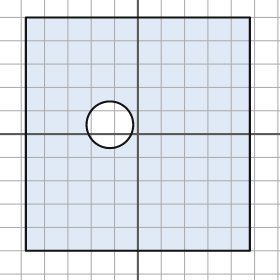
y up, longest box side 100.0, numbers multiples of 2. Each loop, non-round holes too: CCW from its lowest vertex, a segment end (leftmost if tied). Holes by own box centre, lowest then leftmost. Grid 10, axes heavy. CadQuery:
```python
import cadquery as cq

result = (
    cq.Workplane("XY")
    .moveTo(-48.0, -50.0)
    .lineTo(48.0, -50.0)
    .lineTo(48.0, 50.0)
    .lineTo(-48.0, 50.0)
    .close()
    .moveTo(-12.0, 4.0)
    .circle(10.0)
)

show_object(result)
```